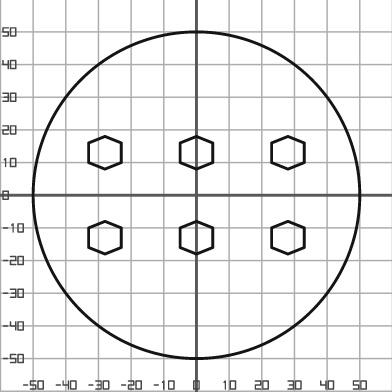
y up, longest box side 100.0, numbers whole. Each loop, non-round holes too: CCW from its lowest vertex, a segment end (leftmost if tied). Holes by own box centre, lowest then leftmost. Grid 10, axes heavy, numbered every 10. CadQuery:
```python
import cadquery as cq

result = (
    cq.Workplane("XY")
    .moveTo(0.0, 0.0)
    .circle(50.0)
    .moveTo(-28.0, -18.0)
    .lineTo(-23.0, -16.0)
    .lineTo(-23.0, -10.0)
    .lineTo(-28.0, -8.0)
    .lineTo(-33.0, -10.0)
    .lineTo(-33.0, -16.0)
    .close()
    .moveTo(0.0, -18.0)
    .lineTo(5.0, -16.0)
    .lineTo(5.0, -10.0)
    .lineTo(0.0, -8.0)
    .lineTo(-5.0, -10.0)
    .lineTo(-5.0, -16.0)
    .close()
    .moveTo(28.0, -18.0)
    .lineTo(33.0, -16.0)
    .lineTo(33.0, -10.0)
    .lineTo(28.0, -8.0)
    .lineTo(23.0, -10.0)
    .lineTo(23.0, -16.0)
    .close()
    .moveTo(-28.0, 8.0)
    .lineTo(-23.0, 10.0)
    .lineTo(-23.0, 16.0)
    .lineTo(-28.0, 18.0)
    .lineTo(-33.0, 16.0)
    .lineTo(-33.0, 10.0)
    .close()
    .moveTo(0.0, 8.0)
    .lineTo(5.0, 10.0)
    .lineTo(5.0, 16.0)
    .lineTo(0.0, 18.0)
    .lineTo(-5.0, 16.0)
    .lineTo(-5.0, 10.0)
    .close()
    .moveTo(28.0, 8.0)
    .lineTo(33.0, 10.0)
    .lineTo(33.0, 16.0)
    .lineTo(28.0, 18.0)
    .lineTo(23.0, 16.0)
    .lineTo(23.0, 10.0)
    .close()
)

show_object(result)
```